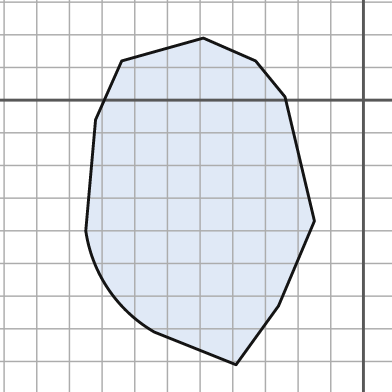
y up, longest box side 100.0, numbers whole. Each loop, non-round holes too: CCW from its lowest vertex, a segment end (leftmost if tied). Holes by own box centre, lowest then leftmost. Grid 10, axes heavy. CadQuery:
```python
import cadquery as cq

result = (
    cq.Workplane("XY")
    .moveTo(-39.0, -81.0)
    .lineTo(-26.0, -63.0)
    .lineTo(-15.0, -37.0)
    .lineTo(-24.0, 1.0)
    .lineTo(-33.0, 12.0)
    .lineTo(-49.0, 19.0)
    .lineTo(-74.0, 12.0)
    .lineTo(-82.0, -6.0)
    .lineTo(-85.0, -40.0)
    .threePointArc((-78.0, -58.0), (-64.0, -71.0))
    .close()
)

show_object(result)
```